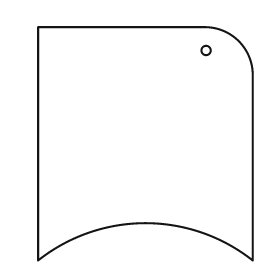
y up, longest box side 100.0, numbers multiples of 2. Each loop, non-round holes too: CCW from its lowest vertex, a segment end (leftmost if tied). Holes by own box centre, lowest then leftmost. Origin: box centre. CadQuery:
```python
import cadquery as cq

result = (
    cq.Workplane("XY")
    .moveTo(-46.0, -50.0)
    .threePointArc((0.0, -34.0), (46.0, -50.0))
    .lineTo(46.0, 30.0)
    .threePointArc((40.0, 44.0), (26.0, 50.0))
    .lineTo(-46.0, 50.0)
    .close()
    .moveTo(26.0, 40.0)
    .circle(2.0)
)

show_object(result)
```